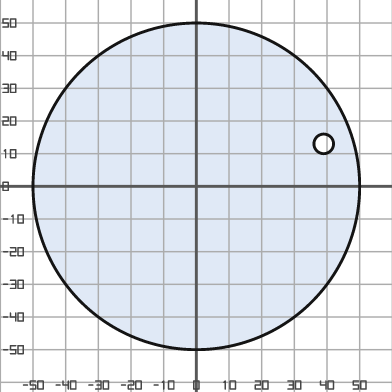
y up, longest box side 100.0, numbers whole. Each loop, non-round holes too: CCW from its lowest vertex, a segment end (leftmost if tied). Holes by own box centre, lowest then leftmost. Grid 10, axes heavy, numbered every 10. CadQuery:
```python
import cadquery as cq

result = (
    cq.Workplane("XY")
    .moveTo(0.0, 0.0)
    .circle(50.0)
    .moveTo(39.0, 13.0)
    .circle(3.0)
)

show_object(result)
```